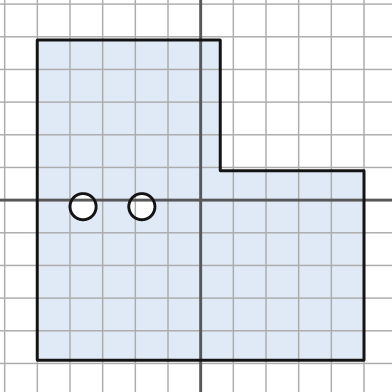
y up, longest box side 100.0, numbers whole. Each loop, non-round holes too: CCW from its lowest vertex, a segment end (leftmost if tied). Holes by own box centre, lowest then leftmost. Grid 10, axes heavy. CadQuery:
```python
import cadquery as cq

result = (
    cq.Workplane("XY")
    .moveTo(-50.0, -49.0)
    .lineTo(50.0, -49.0)
    .lineTo(50.0, 9.0)
    .lineTo(6.0, 9.0)
    .lineTo(6.0, 49.0)
    .lineTo(-50.0, 49.0)
    .close()
    .moveTo(-36.0, -2.0)
    .circle(4.0)
    .moveTo(-18.0, -2.0)
    .circle(4.0)
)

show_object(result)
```